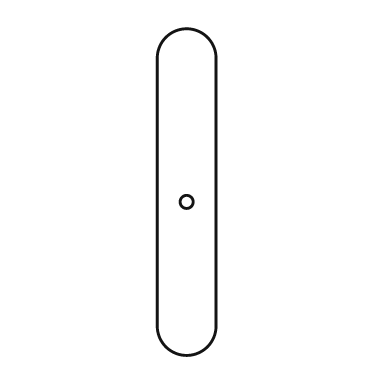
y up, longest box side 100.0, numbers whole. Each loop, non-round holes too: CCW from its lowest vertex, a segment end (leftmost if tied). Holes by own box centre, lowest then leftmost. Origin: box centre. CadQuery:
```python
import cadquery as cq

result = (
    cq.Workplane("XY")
    .moveTo(-9.0, -41.0)
    .threePointArc((0.0, -50.0), (9.0, -41.0))
    .lineTo(9.0, 41.0)
    .threePointArc((0.0, 50.0), (-9.0, 41.0))
    .close()
    .moveTo(0.0, -3.0)
    .circle(2.0)
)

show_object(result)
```